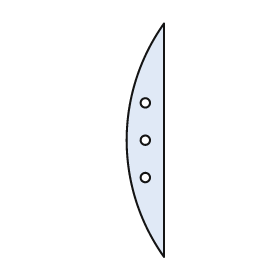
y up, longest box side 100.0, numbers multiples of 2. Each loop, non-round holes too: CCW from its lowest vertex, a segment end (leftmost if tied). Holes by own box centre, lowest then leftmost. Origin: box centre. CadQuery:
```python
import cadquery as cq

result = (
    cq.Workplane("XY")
    .moveTo(8.0, -50.0)
    .lineTo(8.0, 50.0)
    .threePointArc((-8.0, 0.0), (8.0, -50.0))
    .close()
    .moveTo(0.0, -16.0)
    .circle(2.0)
    .moveTo(0.0, 0.0)
    .circle(2.0)
    .moveTo(0.0, 16.0)
    .circle(2.0)
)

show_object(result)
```